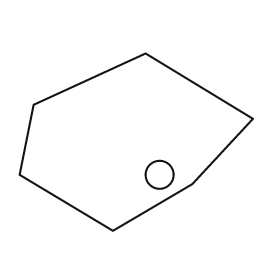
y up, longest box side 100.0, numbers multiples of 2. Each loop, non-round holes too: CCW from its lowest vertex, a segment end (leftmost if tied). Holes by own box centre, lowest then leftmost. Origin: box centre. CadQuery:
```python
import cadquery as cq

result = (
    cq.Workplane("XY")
    .moveTo(-10.0, -38.0)
    .lineTo(24.0, -18.0)
    .lineTo(50.0, 10.0)
    .lineTo(4.0, 38.0)
    .lineTo(-44.0, 16.0)
    .lineTo(-50.0, -14.0)
    .close()
    .moveTo(10.0, -14.0)
    .circle(6.0)
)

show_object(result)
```